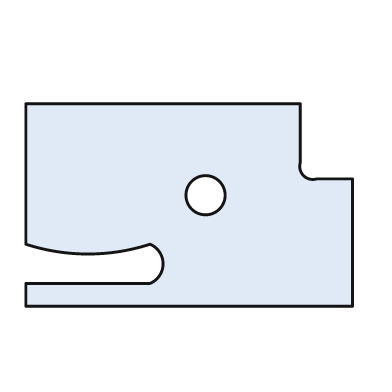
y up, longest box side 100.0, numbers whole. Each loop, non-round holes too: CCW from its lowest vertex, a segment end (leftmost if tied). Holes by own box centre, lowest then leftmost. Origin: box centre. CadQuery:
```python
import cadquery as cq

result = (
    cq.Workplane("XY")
    .moveTo(-50.0, -31.0)
    .lineTo(50.0, -31.0)
    .lineTo(50.0, 8.0)
    .lineTo(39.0, 8.0)
    .threePointArc((35.0, 9.0), (34.0, 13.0))
    .lineTo(34.0, 31.0)
    .lineTo(-50.0, 31.0)
    .lineTo(-50.0, -12.0)
    .threePointArc((-31.0, -15.0), (-12.0, -12.0))
    .threePointArc((-8.0, -18.0), (-12.0, -24.0))
    .lineTo(-50.0, -24.0)
    .close()
    .moveTo(5.0, 3.0)
    .circle(6.0)
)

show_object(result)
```